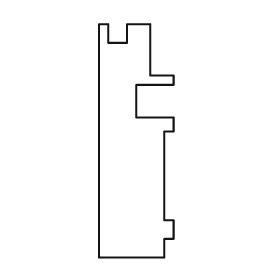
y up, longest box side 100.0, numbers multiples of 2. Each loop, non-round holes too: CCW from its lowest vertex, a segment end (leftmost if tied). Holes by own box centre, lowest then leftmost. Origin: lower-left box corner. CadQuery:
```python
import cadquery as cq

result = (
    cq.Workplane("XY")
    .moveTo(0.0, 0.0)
    .lineTo(28.0, 0.0)
    .lineTo(28.0, 8.0)
    .lineTo(32.0, 8.0)
    .lineTo(32.0, 16.0)
    .lineTo(28.0, 16.0)
    .lineTo(28.0, 54.0)
    .lineTo(32.0, 54.0)
    .lineTo(32.0, 60.0)
    .lineTo(16.0, 60.0)
    .lineTo(16.0, 74.0)
    .lineTo(32.0, 74.0)
    .lineTo(32.0, 78.0)
    .lineTo(22.0, 78.0)
    .lineTo(22.0, 100.0)
    .lineTo(12.0, 100.0)
    .lineTo(12.0, 92.0)
    .lineTo(4.0, 92.0)
    .lineTo(4.0, 100.0)
    .lineTo(0.0, 100.0)
    .close()
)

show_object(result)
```